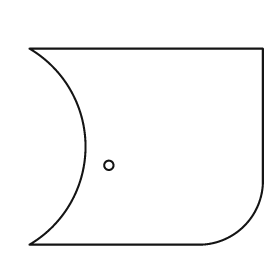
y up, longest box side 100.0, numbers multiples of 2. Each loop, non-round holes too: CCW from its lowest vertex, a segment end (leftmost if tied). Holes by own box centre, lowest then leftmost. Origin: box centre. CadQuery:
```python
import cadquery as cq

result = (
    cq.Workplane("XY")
    .moveTo(-50.0, -42.0)
    .lineTo(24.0, -42.0)
    .threePointArc((42.0, -34.0), (50.0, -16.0))
    .lineTo(50.0, 42.0)
    .lineTo(-50.0, 42.0)
    .threePointArc((-26.0, 0.0), (-50.0, -42.0))
    .close()
    .moveTo(-16.0, -8.0)
    .circle(2.0)
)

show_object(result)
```